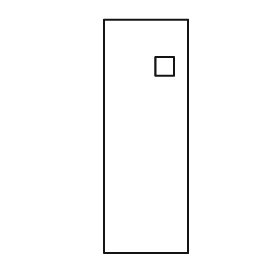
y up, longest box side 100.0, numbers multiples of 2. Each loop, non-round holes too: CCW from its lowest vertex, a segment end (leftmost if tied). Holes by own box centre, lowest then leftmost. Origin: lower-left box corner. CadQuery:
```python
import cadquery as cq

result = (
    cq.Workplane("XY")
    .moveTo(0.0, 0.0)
    .lineTo(36.0, 0.0)
    .lineTo(36.0, 100.0)
    .lineTo(0.0, 100.0)
    .close()
    .moveTo(22.0, 76.0)
    .lineTo(30.0, 76.0)
    .lineTo(30.0, 84.0)
    .lineTo(22.0, 84.0)
    .close()
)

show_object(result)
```